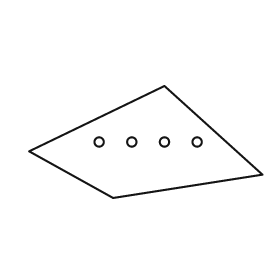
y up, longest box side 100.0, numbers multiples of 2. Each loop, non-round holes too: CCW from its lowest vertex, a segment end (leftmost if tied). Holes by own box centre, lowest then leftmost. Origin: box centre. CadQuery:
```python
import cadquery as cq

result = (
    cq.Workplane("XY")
    .moveTo(-14.0, -24.0)
    .lineTo(50.0, -14.0)
    .lineTo(8.0, 24.0)
    .lineTo(-50.0, -4.0)
    .close()
    .moveTo(-20.0, 0.0)
    .circle(2.0)
    .moveTo(-6.0, 0.0)
    .circle(2.0)
    .moveTo(8.0, 0.0)
    .circle(2.0)
    .moveTo(22.0, 0.0)
    .circle(2.0)
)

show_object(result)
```